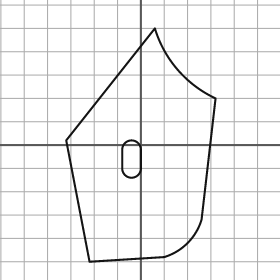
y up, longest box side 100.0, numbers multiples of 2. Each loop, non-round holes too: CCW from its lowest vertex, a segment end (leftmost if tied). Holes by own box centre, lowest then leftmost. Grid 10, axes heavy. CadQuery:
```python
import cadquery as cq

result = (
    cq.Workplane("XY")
    .moveTo(-22.0, -50.0)
    .lineTo(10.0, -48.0)
    .threePointArc((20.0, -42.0), (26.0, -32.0))
    .lineTo(32.0, 20.0)
    .threePointArc((16.0, 32.0), (6.0, 50.0))
    .lineTo(-32.0, 2.0)
    .close()
    .moveTo(-8.0, -10.0)
    .threePointArc((-4.0, -14.0), (0.0, -10.0))
    .lineTo(0.0, -2.0)
    .threePointArc((-4.0, 2.0), (-8.0, -2.0))
    .close()
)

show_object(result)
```